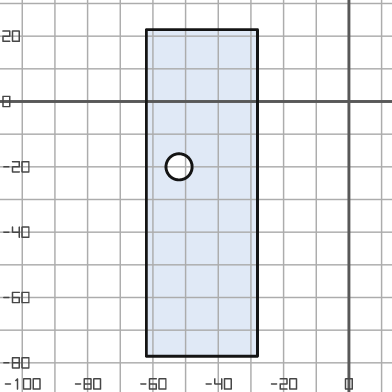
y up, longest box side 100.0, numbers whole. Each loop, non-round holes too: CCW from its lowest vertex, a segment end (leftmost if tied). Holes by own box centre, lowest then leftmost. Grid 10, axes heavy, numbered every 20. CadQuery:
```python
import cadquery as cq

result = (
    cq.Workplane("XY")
    .moveTo(-62.0, -78.0)
    .lineTo(-28.0, -78.0)
    .lineTo(-28.0, 22.0)
    .lineTo(-62.0, 22.0)
    .close()
    .moveTo(-52.0, -20.0)
    .circle(4.0)
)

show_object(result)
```